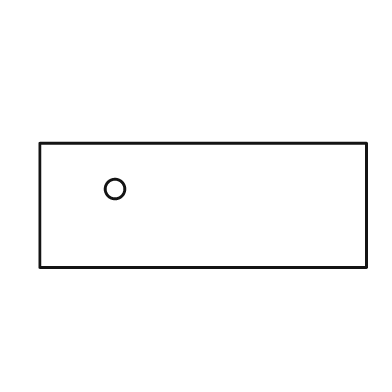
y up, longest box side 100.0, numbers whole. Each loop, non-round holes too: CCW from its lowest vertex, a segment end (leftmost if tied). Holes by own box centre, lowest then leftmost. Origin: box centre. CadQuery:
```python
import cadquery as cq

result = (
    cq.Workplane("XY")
    .moveTo(-50.0, -19.0)
    .lineTo(50.0, -19.0)
    .lineTo(50.0, 19.0)
    .lineTo(-50.0, 19.0)
    .close()
    .moveTo(-27.0, 5.0)
    .circle(3.0)
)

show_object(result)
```